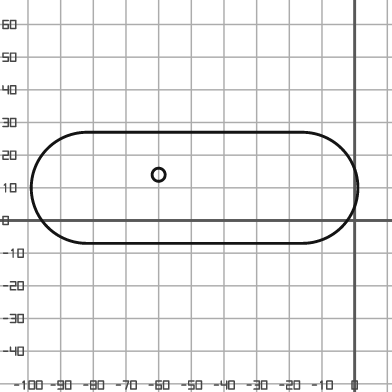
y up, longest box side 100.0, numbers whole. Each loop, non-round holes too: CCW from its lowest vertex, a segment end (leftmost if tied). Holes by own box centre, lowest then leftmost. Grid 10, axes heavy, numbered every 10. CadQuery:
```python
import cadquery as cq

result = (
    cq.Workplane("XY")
    .moveTo(-82.0, -7.0)
    .lineTo(-16.0, -7.0)
    .threePointArc((1.0, 10.0), (-16.0, 27.0))
    .lineTo(-82.0, 27.0)
    .threePointArc((-99.0, 10.0), (-82.0, -7.0))
    .close()
    .moveTo(-60.0, 14.0)
    .circle(2.0)
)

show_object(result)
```